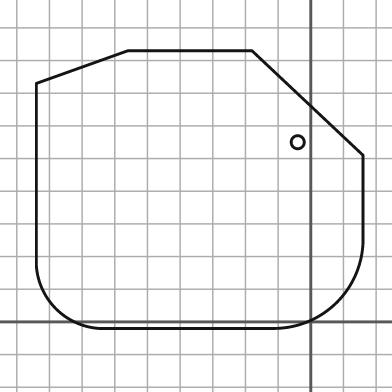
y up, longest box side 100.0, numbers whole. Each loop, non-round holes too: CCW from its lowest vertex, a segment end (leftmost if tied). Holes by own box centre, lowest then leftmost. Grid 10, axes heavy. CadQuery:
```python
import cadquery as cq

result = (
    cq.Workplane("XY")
    .moveTo(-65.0, -2.0)
    .lineTo(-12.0, -2.0)
    .threePointArc((8.0, 6.0), (16.0, 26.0))
    .lineTo(16.0, 51.0)
    .lineTo(-18.0, 83.0)
    .lineTo(-56.0, 83.0)
    .lineTo(-84.0, 73.0)
    .lineTo(-84.0, 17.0)
    .threePointArc((-78.0, 4.0), (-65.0, -2.0))
    .close()
    .moveTo(-4.0, 55.0)
    .circle(2.0)
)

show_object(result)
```